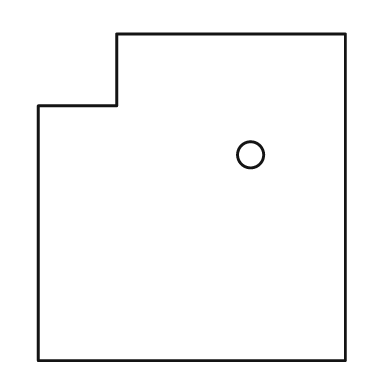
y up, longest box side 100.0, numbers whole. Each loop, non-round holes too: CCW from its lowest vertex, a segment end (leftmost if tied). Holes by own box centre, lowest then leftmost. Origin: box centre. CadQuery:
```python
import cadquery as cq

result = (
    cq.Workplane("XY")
    .moveTo(-47.0, -50.0)
    .lineTo(47.0, -50.0)
    .lineTo(47.0, 50.0)
    .lineTo(-23.0, 50.0)
    .lineTo(-23.0, 28.0)
    .lineTo(-47.0, 28.0)
    .close()
    .moveTo(18.0, 13.0)
    .circle(4.0)
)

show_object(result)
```